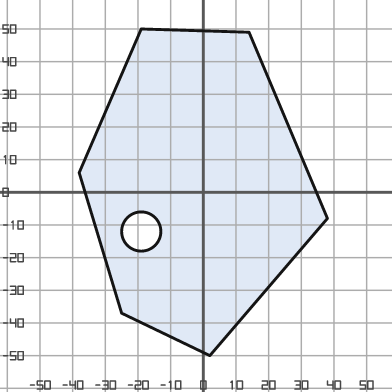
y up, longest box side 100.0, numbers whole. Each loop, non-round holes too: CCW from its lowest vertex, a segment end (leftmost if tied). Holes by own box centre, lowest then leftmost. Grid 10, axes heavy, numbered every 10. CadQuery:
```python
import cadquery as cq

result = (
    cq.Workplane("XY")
    .moveTo(2.0, -50.0)
    .lineTo(38.0, -8.0)
    .lineTo(14.0, 49.0)
    .lineTo(-19.0, 50.0)
    .lineTo(-38.0, 6.0)
    .lineTo(-25.0, -37.0)
    .close()
    .moveTo(-19.0, -12.0)
    .circle(6.0)
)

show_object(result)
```